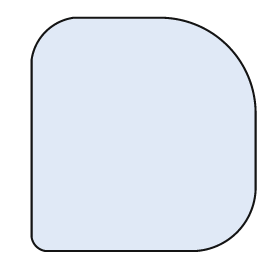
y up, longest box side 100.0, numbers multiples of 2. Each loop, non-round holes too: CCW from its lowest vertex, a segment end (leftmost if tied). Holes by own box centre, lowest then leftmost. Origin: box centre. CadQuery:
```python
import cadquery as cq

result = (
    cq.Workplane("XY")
    .moveTo(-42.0, -50.0)
    .lineTo(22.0, -50.0)
    .threePointArc((40.0, -42.0), (48.0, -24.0))
    .lineTo(48.0, 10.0)
    .threePointArc((36.0, 38.0), (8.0, 50.0))
    .lineTo(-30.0, 50.0)
    .threePointArc((-42.0, 44.0), (-48.0, 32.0))
    .lineTo(-48.0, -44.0)
    .threePointArc((-46.0, -48.0), (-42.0, -50.0))
    .close()
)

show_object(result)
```